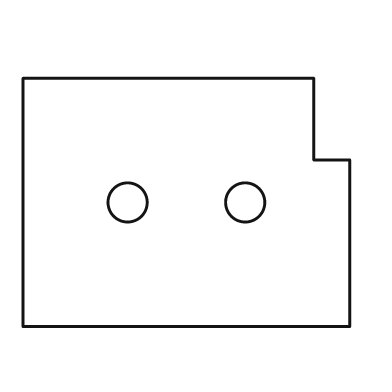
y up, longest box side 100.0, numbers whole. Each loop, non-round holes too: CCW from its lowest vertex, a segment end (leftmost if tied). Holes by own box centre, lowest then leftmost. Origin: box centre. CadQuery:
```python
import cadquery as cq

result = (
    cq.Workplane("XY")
    .moveTo(-50.0, -38.0)
    .lineTo(50.0, -38.0)
    .lineTo(50.0, 13.0)
    .lineTo(39.0, 13.0)
    .lineTo(39.0, 38.0)
    .lineTo(-50.0, 38.0)
    .close()
    .moveTo(-18.0, 0.0)
    .circle(6.0)
    .moveTo(18.0, 0.0)
    .circle(6.0)
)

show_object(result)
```